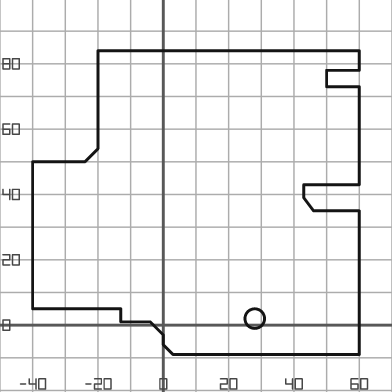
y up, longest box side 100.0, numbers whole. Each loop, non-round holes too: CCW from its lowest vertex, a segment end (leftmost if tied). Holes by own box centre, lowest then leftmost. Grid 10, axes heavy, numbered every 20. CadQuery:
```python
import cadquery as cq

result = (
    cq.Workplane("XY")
    .moveTo(3.0, -9.0)
    .lineTo(60.0, -9.0)
    .lineTo(60.0, 35.0)
    .lineTo(46.0, 35.0)
    .lineTo(43.0, 39.0)
    .lineTo(43.0, 43.0)
    .lineTo(60.0, 43.0)
    .lineTo(60.0, 73.0)
    .lineTo(50.0, 73.0)
    .lineTo(50.0, 78.0)
    .lineTo(60.0, 78.0)
    .lineTo(60.0, 84.0)
    .lineTo(-20.0, 84.0)
    .lineTo(-20.0, 54.0)
    .lineTo(-24.0, 50.0)
    .lineTo(-40.0, 50.0)
    .lineTo(-40.0, 5.0)
    .lineTo(-13.0, 5.0)
    .lineTo(-13.0, 1.0)
    .lineTo(-4.0, 1.0)
    .lineTo(0.0, -3.0)
    .lineTo(0.0, -6.0)
    .close()
    .moveTo(28.0, 2.0)
    .circle(3.0)
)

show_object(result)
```